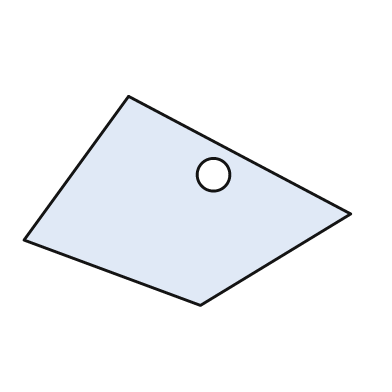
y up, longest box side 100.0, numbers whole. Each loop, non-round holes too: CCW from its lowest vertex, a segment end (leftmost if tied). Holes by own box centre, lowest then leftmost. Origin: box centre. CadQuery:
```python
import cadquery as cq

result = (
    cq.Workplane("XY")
    .moveTo(4.0, -32.0)
    .lineTo(50.0, -4.0)
    .lineTo(-18.0, 32.0)
    .lineTo(-50.0, -12.0)
    .close()
    .moveTo(8.0, 8.0)
    .circle(5.0)
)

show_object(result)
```